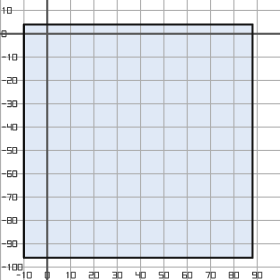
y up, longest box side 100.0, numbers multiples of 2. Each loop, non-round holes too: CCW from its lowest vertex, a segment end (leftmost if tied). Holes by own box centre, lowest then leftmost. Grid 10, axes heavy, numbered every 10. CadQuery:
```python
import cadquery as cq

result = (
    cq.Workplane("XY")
    .moveTo(-10.0, -96.0)
    .lineTo(88.0, -96.0)
    .lineTo(88.0, 4.0)
    .lineTo(-10.0, 4.0)
    .close()
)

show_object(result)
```